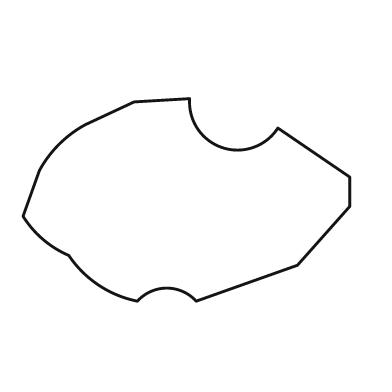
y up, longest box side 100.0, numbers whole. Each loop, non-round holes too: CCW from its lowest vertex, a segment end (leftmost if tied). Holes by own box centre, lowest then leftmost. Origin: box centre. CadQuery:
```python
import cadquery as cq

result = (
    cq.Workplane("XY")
    .moveTo(-15.0, -31.0)
    .threePointArc((-6.0, -27.0), (3.0, -31.0))
    .lineTo(34.0, -20.0)
    .lineTo(50.0, -2.0)
    .lineTo(50.0, 7.0)
    .lineTo(28.0, 22.0)
    .threePointArc((11.0, 16.0), (1.0, 31.0))
    .lineTo(-16.0, 30.0)
    .lineTo(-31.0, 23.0)
    .threePointArc((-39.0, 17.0), (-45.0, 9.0))
    .lineTo(-50.0, -5.0)
    .threePointArc((-44.0, -12.0), (-36.0, -17.0))
    .threePointArc((-27.0, -26.0), (-15.0, -31.0))
    .close()
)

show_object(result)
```